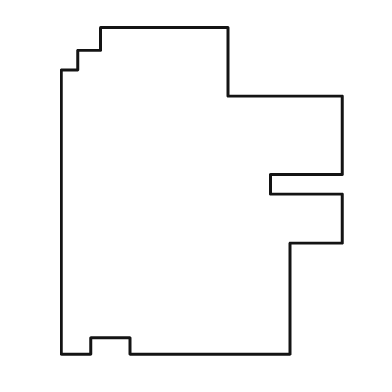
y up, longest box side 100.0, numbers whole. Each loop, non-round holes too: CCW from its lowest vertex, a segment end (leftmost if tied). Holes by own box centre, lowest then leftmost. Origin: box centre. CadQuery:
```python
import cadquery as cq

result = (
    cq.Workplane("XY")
    .moveTo(-43.0, -50.0)
    .lineTo(-34.0, -50.0)
    .lineTo(-34.0, -45.0)
    .lineTo(-22.0, -45.0)
    .lineTo(-22.0, -50.0)
    .lineTo(27.0, -50.0)
    .lineTo(27.0, -16.0)
    .lineTo(43.0, -16.0)
    .lineTo(43.0, -1.0)
    .lineTo(21.0, -1.0)
    .lineTo(21.0, 5.0)
    .lineTo(43.0, 5.0)
    .lineTo(43.0, 29.0)
    .lineTo(8.0, 29.0)
    .lineTo(8.0, 50.0)
    .lineTo(-31.0, 50.0)
    .lineTo(-31.0, 43.0)
    .lineTo(-38.0, 43.0)
    .lineTo(-38.0, 37.0)
    .lineTo(-43.0, 37.0)
    .close()
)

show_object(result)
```